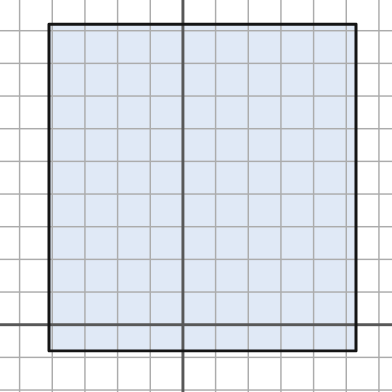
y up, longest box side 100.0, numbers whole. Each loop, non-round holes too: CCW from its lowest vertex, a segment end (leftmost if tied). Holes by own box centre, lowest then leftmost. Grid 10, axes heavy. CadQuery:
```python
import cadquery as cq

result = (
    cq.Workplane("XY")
    .moveTo(-41.0, -8.0)
    .lineTo(53.0, -8.0)
    .lineTo(53.0, 92.0)
    .lineTo(-41.0, 92.0)
    .close()
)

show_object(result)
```